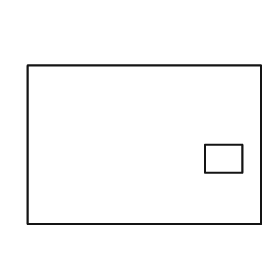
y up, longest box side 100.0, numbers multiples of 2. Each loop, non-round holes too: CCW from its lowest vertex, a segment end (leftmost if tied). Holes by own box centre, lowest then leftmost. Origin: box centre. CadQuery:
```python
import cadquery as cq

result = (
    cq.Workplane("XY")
    .moveTo(-50.0, -34.0)
    .lineTo(50.0, -34.0)
    .lineTo(50.0, 34.0)
    .lineTo(-50.0, 34.0)
    .close()
    .moveTo(26.0, -12.0)
    .lineTo(42.0, -12.0)
    .lineTo(42.0, 0.0)
    .lineTo(26.0, 0.0)
    .close()
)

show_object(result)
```